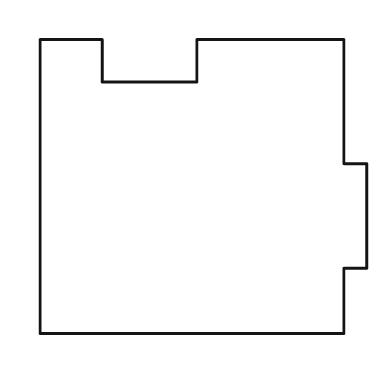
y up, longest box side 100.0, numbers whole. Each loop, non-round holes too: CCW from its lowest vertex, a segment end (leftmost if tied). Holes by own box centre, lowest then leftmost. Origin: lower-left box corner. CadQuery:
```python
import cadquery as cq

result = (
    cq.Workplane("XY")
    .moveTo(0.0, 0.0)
    .lineTo(93.0, 0.0)
    .lineTo(93.0, 20.0)
    .lineTo(100.0, 20.0)
    .lineTo(100.0, 52.0)
    .lineTo(93.0, 52.0)
    .lineTo(93.0, 90.0)
    .lineTo(48.0, 90.0)
    .lineTo(48.0, 77.0)
    .lineTo(19.0, 77.0)
    .lineTo(19.0, 90.0)
    .lineTo(0.0, 90.0)
    .close()
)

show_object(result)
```